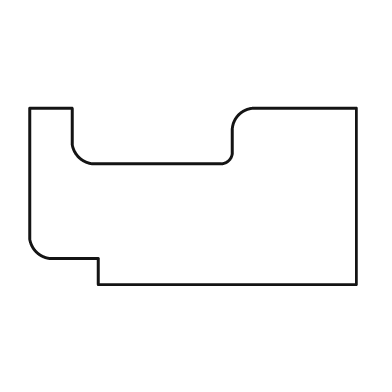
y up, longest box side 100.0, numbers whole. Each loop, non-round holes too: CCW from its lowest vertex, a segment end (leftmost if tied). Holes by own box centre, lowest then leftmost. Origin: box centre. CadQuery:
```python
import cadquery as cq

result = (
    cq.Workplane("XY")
    .moveTo(-29.0, -27.0)
    .lineTo(50.0, -27.0)
    .lineTo(50.0, 27.0)
    .lineTo(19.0, 27.0)
    .threePointArc((14.0, 25.0), (12.0, 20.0))
    .lineTo(12.0, 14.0)
    .threePointArc((11.0, 11.0), (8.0, 10.0))
    .lineTo(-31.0, 10.0)
    .threePointArc((-35.0, 12.0), (-37.0, 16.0))
    .lineTo(-37.0, 27.0)
    .lineTo(-50.0, 27.0)
    .lineTo(-50.0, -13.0)
    .threePointArc((-48.0, -17.0), (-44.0, -19.0))
    .lineTo(-29.0, -19.0)
    .close()
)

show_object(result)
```